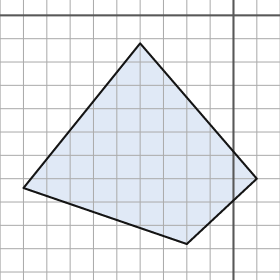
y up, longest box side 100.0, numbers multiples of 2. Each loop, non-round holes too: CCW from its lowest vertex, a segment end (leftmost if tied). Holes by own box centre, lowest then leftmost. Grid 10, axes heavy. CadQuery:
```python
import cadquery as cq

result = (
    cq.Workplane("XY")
    .moveTo(-20.0, -98.0)
    .lineTo(10.0, -70.0)
    .lineTo(-40.0, -12.0)
    .lineTo(-90.0, -74.0)
    .close()
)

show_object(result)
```